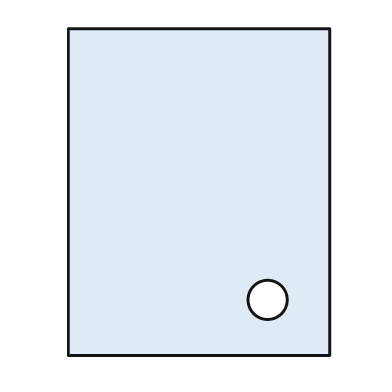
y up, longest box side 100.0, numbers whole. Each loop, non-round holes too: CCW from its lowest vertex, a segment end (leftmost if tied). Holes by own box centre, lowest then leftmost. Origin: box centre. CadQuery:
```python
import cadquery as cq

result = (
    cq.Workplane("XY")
    .moveTo(-40.0, -50.0)
    .lineTo(40.0, -50.0)
    .lineTo(40.0, 50.0)
    .lineTo(-40.0, 50.0)
    .close()
    .moveTo(21.0, -33.0)
    .circle(6.0)
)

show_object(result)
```